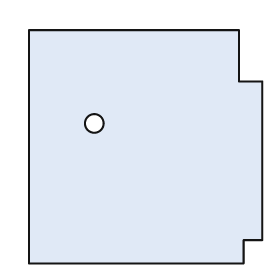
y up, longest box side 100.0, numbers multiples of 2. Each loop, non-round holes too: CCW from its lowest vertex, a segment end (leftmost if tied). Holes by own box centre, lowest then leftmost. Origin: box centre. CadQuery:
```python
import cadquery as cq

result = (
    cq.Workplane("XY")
    .moveTo(-50.0, -50.0)
    .lineTo(42.0, -50.0)
    .lineTo(42.0, -40.0)
    .lineTo(50.0, -40.0)
    .lineTo(50.0, 28.0)
    .lineTo(40.0, 28.0)
    .lineTo(40.0, 50.0)
    .lineTo(-50.0, 50.0)
    .close()
    .moveTo(-22.0, 10.0)
    .circle(4.0)
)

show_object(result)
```